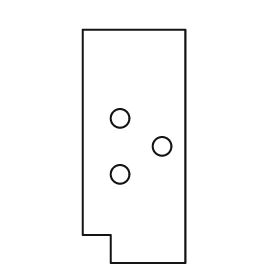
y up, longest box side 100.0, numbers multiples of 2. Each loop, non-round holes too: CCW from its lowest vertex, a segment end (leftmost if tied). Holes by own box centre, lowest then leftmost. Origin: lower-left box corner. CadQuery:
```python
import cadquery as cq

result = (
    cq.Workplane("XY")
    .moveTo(12.0, 0.0)
    .lineTo(44.0, 0.0)
    .lineTo(44.0, 100.0)
    .lineTo(0.0, 100.0)
    .lineTo(0.0, 12.0)
    .lineTo(12.0, 12.0)
    .close()
    .moveTo(16.0, 38.0)
    .circle(4.0)
    .moveTo(34.0, 50.0)
    .circle(4.0)
    .moveTo(16.0, 62.0)
    .circle(4.0)
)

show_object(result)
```